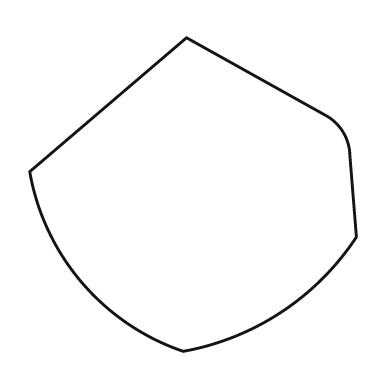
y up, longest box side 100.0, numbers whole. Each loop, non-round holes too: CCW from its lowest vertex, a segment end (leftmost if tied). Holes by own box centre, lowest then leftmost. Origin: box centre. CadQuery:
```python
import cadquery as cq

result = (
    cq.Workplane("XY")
    .moveTo(-3.0, -48.0)
    .threePointArc((27.0, -36.0), (50.0, -13.0))
    .lineTo(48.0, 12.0)
    .threePointArc((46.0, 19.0), (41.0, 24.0))
    .lineTo(-2.0, 48.0)
    .lineTo(-50.0, 7.0)
    .threePointArc((-34.0, -27.0), (-3.0, -48.0))
    .close()
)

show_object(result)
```